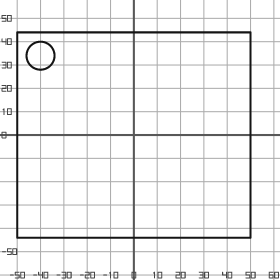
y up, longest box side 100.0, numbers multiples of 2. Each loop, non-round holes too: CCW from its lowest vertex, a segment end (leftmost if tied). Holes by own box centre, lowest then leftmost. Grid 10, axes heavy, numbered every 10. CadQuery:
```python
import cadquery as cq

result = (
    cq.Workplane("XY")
    .moveTo(-50.0, -44.0)
    .lineTo(50.0, -44.0)
    .lineTo(50.0, 44.0)
    .lineTo(-50.0, 44.0)
    .close()
    .moveTo(-40.0, 34.0)
    .circle(6.0)
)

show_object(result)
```